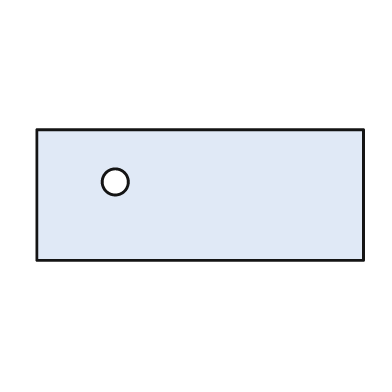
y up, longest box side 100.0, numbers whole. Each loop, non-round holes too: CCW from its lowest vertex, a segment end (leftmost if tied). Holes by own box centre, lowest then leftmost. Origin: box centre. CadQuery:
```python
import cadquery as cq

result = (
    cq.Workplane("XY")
    .moveTo(-50.0, -20.0)
    .lineTo(50.0, -20.0)
    .lineTo(50.0, 20.0)
    .lineTo(-50.0, 20.0)
    .close()
    .moveTo(-26.0, 4.0)
    .circle(4.0)
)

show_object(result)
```